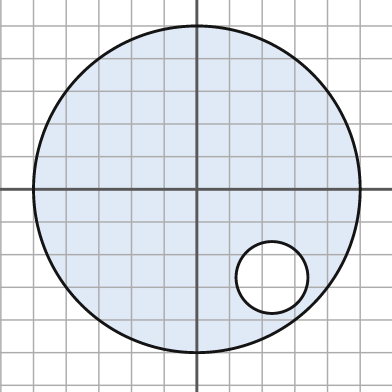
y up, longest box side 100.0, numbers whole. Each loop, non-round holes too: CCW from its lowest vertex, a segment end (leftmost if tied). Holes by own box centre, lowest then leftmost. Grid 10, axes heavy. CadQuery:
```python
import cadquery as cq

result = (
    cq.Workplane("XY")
    .moveTo(0.0, 0.0)
    .circle(50.0)
    .moveTo(23.0, -27.0)
    .circle(11.0)
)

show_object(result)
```